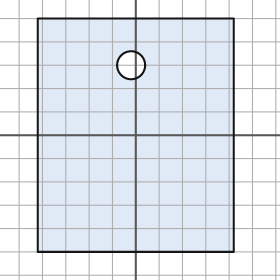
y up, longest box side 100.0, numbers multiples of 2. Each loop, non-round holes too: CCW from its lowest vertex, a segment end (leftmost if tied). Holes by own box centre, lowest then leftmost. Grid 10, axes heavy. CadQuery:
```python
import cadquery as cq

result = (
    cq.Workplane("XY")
    .moveTo(-42.0, -50.0)
    .lineTo(42.0, -50.0)
    .lineTo(42.0, 50.0)
    .lineTo(-42.0, 50.0)
    .close()
    .moveTo(-2.0, 30.0)
    .circle(6.0)
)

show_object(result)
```